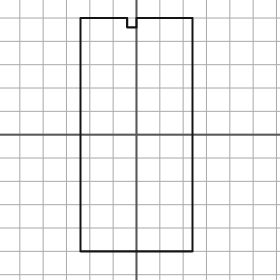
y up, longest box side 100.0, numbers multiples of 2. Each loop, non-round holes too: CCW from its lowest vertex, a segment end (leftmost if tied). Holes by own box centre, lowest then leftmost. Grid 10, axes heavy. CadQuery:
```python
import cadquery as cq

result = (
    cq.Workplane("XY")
    .moveTo(-24.0, -50.0)
    .lineTo(24.0, -50.0)
    .lineTo(24.0, 50.0)
    .lineTo(0.0, 50.0)
    .lineTo(0.0, 46.0)
    .lineTo(-4.0, 46.0)
    .lineTo(-4.0, 50.0)
    .lineTo(-24.0, 50.0)
    .close()
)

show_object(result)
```